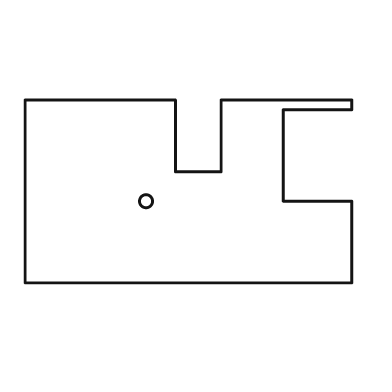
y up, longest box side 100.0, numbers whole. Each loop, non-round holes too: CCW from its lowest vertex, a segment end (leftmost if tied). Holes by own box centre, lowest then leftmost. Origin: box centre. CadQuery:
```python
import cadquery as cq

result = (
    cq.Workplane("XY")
    .moveTo(-50.0, -28.0)
    .lineTo(50.0, -28.0)
    .lineTo(50.0, -3.0)
    .lineTo(29.0, -3.0)
    .lineTo(29.0, 25.0)
    .lineTo(50.0, 25.0)
    .lineTo(50.0, 28.0)
    .lineTo(10.0, 28.0)
    .lineTo(10.0, 6.0)
    .lineTo(-4.0, 6.0)
    .lineTo(-4.0, 28.0)
    .lineTo(-50.0, 28.0)
    .close()
    .moveTo(-13.0, -3.0)
    .circle(2.0)
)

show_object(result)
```